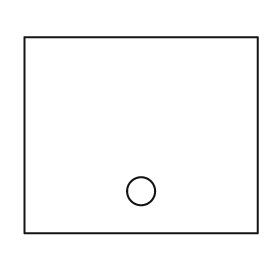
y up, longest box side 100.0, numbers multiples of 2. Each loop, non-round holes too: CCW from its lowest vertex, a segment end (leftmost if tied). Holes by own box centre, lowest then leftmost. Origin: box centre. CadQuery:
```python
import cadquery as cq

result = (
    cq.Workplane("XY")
    .moveTo(-50.0, -42.0)
    .lineTo(50.0, -42.0)
    .lineTo(50.0, 42.0)
    .lineTo(-50.0, 42.0)
    .close()
    .moveTo(0.0, -24.0)
    .circle(6.0)
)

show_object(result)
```